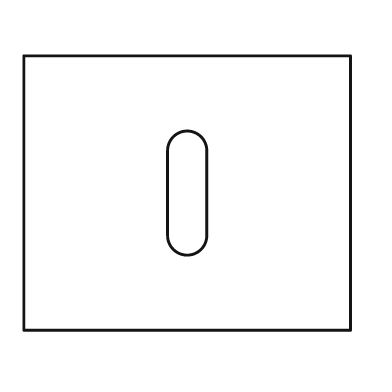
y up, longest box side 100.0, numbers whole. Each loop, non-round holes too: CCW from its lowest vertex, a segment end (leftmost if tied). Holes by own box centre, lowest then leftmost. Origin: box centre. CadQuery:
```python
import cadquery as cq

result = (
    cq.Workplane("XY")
    .moveTo(-50.0, -42.0)
    .lineTo(50.0, -42.0)
    .lineTo(50.0, 42.0)
    .lineTo(-50.0, 42.0)
    .close()
    .moveTo(-6.0, -13.0)
    .threePointArc((0.0, -19.0), (6.0, -13.0))
    .lineTo(6.0, 13.0)
    .threePointArc((0.0, 19.0), (-6.0, 13.0))
    .close()
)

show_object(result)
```